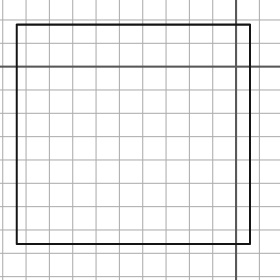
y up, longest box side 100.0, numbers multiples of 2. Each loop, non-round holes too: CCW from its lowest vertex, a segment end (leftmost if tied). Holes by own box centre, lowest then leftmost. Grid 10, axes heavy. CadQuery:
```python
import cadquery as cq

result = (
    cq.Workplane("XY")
    .moveTo(-94.0, -76.0)
    .lineTo(6.0, -76.0)
    .lineTo(6.0, 18.0)
    .lineTo(-94.0, 18.0)
    .close()
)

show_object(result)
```